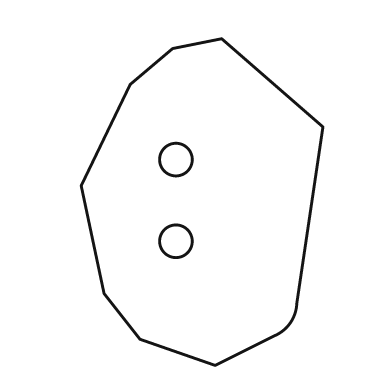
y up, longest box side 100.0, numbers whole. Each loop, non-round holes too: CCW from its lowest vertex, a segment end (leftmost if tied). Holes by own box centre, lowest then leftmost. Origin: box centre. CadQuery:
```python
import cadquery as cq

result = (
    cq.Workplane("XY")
    .moveTo(4.0, -50.0)
    .lineTo(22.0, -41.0)
    .threePointArc((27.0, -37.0), (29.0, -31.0))
    .lineTo(37.0, 23.0)
    .lineTo(6.0, 50.0)
    .lineTo(-9.0, 47.0)
    .lineTo(-22.0, 36.0)
    .lineTo(-37.0, 5.0)
    .lineTo(-30.0, -28.0)
    .lineTo(-19.0, -42.0)
    .close()
    .moveTo(-8.0, -12.0)
    .circle(5.0)
    .moveTo(-8.0, 13.0)
    .circle(5.0)
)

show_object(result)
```